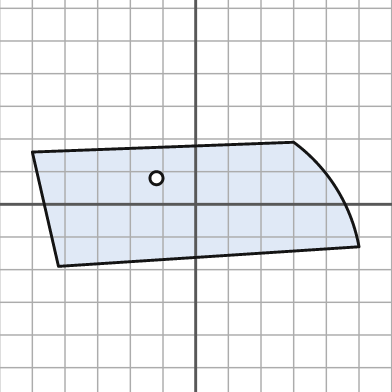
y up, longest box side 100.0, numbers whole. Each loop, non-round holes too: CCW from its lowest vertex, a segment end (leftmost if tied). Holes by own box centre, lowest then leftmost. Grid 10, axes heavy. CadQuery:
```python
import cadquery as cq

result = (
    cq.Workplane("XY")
    .moveTo(-42.0, -19.0)
    .lineTo(50.0, -13.0)
    .threePointArc((43.0, 5.0), (30.0, 19.0))
    .lineTo(-50.0, 16.0)
    .close()
    .moveTo(-12.0, 8.0)
    .circle(2.0)
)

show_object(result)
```